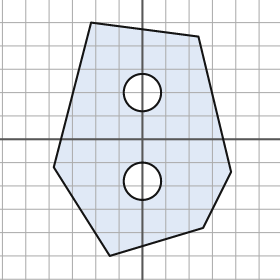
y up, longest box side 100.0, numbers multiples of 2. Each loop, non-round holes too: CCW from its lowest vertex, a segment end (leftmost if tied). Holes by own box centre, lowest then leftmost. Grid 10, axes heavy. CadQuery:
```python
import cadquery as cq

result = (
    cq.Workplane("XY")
    .moveTo(-14.0, -50.0)
    .lineTo(26.0, -38.0)
    .lineTo(38.0, -14.0)
    .lineTo(24.0, 44.0)
    .lineTo(-22.0, 50.0)
    .lineTo(-38.0, -12.0)
    .close()
    .moveTo(0.0, -18.0)
    .circle(8.0)
    .moveTo(0.0, 20.0)
    .circle(8.0)
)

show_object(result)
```